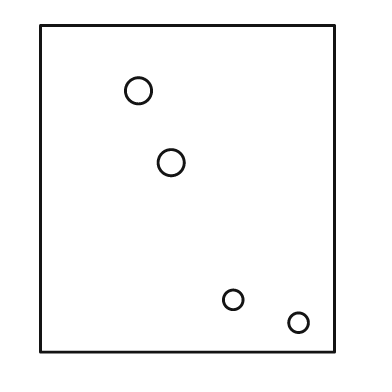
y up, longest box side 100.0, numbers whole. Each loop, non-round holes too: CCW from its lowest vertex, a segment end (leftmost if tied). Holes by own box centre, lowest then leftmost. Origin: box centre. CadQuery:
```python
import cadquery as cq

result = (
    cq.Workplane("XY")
    .moveTo(-45.0, -50.0)
    .lineTo(45.0, -50.0)
    .lineTo(45.0, 50.0)
    .lineTo(-45.0, 50.0)
    .close()
    .moveTo(34.0, -41.0)
    .circle(3.0)
    .moveTo(14.0, -34.0)
    .circle(3.0)
    .moveTo(-5.0, 8.0)
    .circle(4.0)
    .moveTo(-15.0, 30.0)
    .circle(4.0)
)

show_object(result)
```